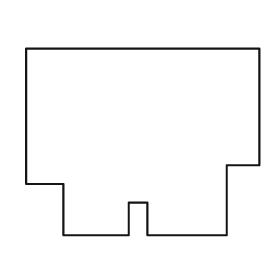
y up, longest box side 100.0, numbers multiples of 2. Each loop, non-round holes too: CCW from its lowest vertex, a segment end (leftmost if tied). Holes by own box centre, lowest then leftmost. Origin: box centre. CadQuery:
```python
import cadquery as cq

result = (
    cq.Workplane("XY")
    .moveTo(-34.0, -40.0)
    .lineTo(-6.0, -40.0)
    .lineTo(-6.0, -26.0)
    .lineTo(2.0, -26.0)
    .lineTo(2.0, -40.0)
    .lineTo(36.0, -40.0)
    .lineTo(36.0, -10.0)
    .lineTo(50.0, -10.0)
    .lineTo(50.0, 40.0)
    .lineTo(-50.0, 40.0)
    .lineTo(-50.0, -18.0)
    .lineTo(-34.0, -18.0)
    .close()
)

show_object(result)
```